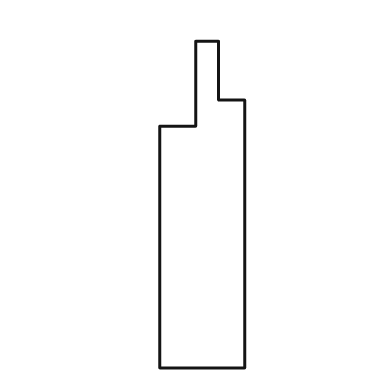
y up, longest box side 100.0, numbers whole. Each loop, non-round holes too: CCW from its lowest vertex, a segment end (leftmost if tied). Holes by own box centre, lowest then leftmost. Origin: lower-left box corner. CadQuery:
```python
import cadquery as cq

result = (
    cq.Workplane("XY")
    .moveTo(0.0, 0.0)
    .lineTo(26.0, 0.0)
    .lineTo(26.0, 82.0)
    .lineTo(18.0, 82.0)
    .lineTo(18.0, 100.0)
    .lineTo(11.0, 100.0)
    .lineTo(11.0, 74.0)
    .lineTo(0.0, 74.0)
    .close()
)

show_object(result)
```